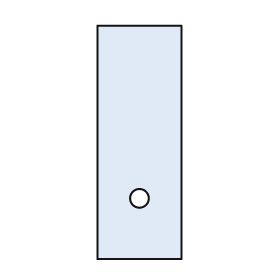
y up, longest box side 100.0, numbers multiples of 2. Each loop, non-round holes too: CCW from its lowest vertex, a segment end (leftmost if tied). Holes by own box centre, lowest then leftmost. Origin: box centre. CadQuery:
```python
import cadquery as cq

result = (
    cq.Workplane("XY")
    .moveTo(-18.0, -50.0)
    .lineTo(18.0, -50.0)
    .lineTo(18.0, 50.0)
    .lineTo(-18.0, 50.0)
    .close()
    .moveTo(0.0, -24.0)
    .circle(4.0)
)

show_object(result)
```